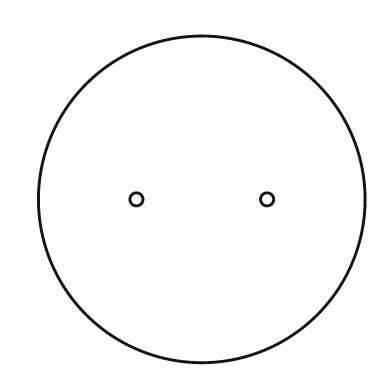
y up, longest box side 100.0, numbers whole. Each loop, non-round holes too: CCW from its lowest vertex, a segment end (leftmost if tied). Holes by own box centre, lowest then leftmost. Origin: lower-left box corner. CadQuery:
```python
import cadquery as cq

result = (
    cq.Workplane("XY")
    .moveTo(50.0, 50.0)
    .circle(50.0)
    .moveTo(30.0, 50.0)
    .circle(2.0)
    .moveTo(70.0, 50.0)
    .circle(2.0)
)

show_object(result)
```